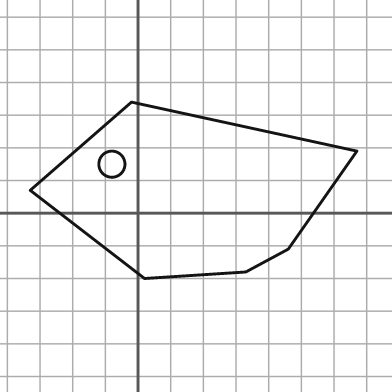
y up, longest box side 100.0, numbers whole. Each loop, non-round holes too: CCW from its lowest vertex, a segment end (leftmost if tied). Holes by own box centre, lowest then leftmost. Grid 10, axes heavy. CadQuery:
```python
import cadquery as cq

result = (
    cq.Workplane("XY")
    .moveTo(2.0, -20.0)
    .lineTo(33.0, -18.0)
    .lineTo(46.0, -11.0)
    .lineTo(67.0, 19.0)
    .lineTo(-2.0, 34.0)
    .lineTo(-33.0, 7.0)
    .close()
    .moveTo(-8.0, 15.0)
    .circle(4.0)
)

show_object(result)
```